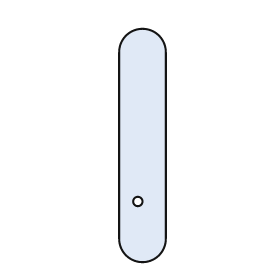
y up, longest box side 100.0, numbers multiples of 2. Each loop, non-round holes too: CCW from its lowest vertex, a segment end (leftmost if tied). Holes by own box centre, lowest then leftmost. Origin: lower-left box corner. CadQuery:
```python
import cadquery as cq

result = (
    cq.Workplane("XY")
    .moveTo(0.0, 10.0)
    .threePointArc((10.0, 0.0), (20.0, 10.0))
    .lineTo(20.0, 90.0)
    .threePointArc((10.0, 100.0), (0.0, 90.0))
    .close()
    .moveTo(8.0, 26.0)
    .circle(2.0)
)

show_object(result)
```